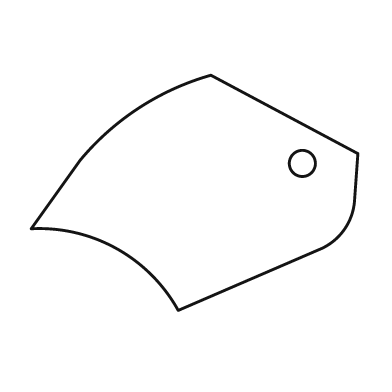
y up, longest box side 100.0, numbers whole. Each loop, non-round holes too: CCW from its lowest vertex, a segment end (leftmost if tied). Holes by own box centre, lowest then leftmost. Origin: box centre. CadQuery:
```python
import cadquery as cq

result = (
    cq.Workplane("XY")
    .moveTo(-5.0, -36.0)
    .lineTo(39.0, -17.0)
    .threePointArc((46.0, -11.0), (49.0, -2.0))
    .lineTo(50.0, 12.0)
    .lineTo(5.0, 36.0)
    .threePointArc((-17.0, 26.0), (-35.0, 10.0))
    .lineTo(-50.0, -11.0)
    .threePointArc((-24.0, -17.0), (-5.0, -36.0))
    .close()
    .moveTo(33.0, 9.0)
    .circle(4.0)
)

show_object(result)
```